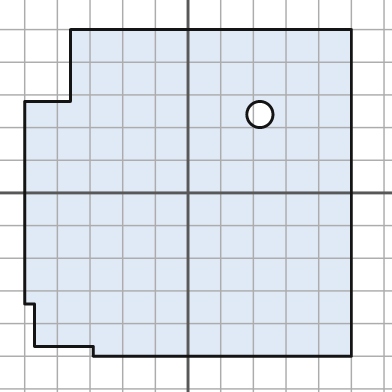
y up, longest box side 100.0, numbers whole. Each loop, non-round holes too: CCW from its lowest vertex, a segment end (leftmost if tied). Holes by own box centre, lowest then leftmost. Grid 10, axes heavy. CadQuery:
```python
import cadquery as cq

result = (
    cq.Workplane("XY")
    .moveTo(-29.0, -50.0)
    .lineTo(50.0, -50.0)
    .lineTo(50.0, 50.0)
    .lineTo(-36.0, 50.0)
    .lineTo(-36.0, 28.0)
    .lineTo(-50.0, 28.0)
    .lineTo(-50.0, -34.0)
    .lineTo(-47.0, -34.0)
    .lineTo(-47.0, -47.0)
    .lineTo(-29.0, -47.0)
    .close()
    .moveTo(22.0, 24.0)
    .circle(4.0)
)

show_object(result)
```